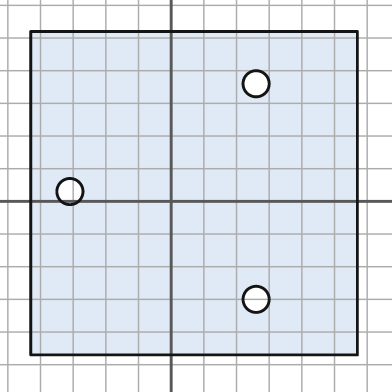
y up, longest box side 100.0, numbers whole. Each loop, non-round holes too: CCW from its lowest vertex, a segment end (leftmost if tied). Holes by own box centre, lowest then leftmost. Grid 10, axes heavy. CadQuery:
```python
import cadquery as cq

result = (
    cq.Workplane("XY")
    .moveTo(-43.0, -47.0)
    .lineTo(57.0, -47.0)
    .lineTo(57.0, 52.0)
    .lineTo(-43.0, 52.0)
    .close()
    .moveTo(26.0, -30.0)
    .circle(4.0)
    .moveTo(-31.0, 3.0)
    .circle(4.0)
    .moveTo(26.0, 36.0)
    .circle(4.0)
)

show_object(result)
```